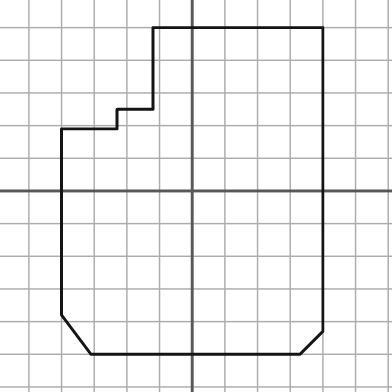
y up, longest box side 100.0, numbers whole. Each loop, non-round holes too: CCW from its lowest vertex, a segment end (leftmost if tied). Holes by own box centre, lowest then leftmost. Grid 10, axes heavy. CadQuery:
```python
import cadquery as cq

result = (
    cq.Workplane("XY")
    .moveTo(-31.0, -50.0)
    .lineTo(33.0, -50.0)
    .lineTo(40.0, -43.0)
    .lineTo(40.0, 50.0)
    .lineTo(-12.0, 50.0)
    .lineTo(-12.0, 25.0)
    .lineTo(-23.0, 25.0)
    .lineTo(-23.0, 19.0)
    .lineTo(-40.0, 19.0)
    .lineTo(-40.0, -38.0)
    .close()
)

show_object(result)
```